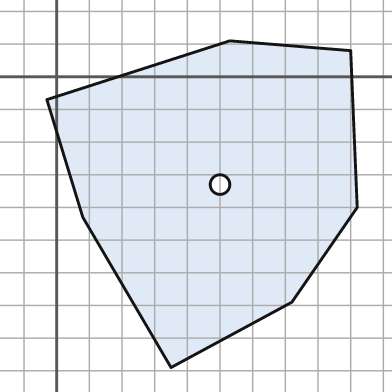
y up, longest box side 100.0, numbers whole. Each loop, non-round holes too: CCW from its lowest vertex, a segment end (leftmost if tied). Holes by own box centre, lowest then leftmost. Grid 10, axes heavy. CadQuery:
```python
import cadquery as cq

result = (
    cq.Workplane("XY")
    .moveTo(35.0, -89.0)
    .lineTo(72.0, -69.0)
    .lineTo(92.0, -40.0)
    .lineTo(90.0, 8.0)
    .lineTo(53.0, 11.0)
    .lineTo(-3.0, -7.0)
    .lineTo(8.0, -43.0)
    .close()
    .moveTo(50.0, -33.0)
    .circle(3.0)
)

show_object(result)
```